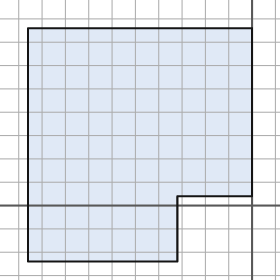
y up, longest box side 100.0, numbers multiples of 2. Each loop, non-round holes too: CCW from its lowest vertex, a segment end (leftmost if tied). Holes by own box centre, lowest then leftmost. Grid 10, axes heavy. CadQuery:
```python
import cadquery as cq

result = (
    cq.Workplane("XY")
    .moveTo(-96.0, -24.0)
    .lineTo(-32.0, -24.0)
    .lineTo(-32.0, 4.0)
    .lineTo(0.0, 4.0)
    .lineTo(0.0, 76.0)
    .lineTo(-96.0, 76.0)
    .close()
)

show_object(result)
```